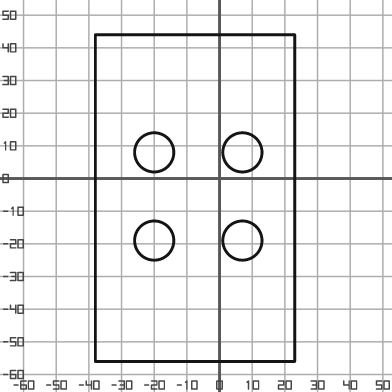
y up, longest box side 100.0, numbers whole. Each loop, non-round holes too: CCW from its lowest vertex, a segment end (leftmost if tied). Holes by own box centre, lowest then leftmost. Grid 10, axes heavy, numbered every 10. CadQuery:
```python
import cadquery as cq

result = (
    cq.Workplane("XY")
    .moveTo(-38.0, -56.0)
    .lineTo(23.0, -56.0)
    .lineTo(23.0, 44.0)
    .lineTo(-38.0, 44.0)
    .close()
    .moveTo(-20.0, -19.0)
    .circle(6.0)
    .moveTo(7.0, -19.0)
    .circle(6.0)
    .moveTo(-20.0, 8.0)
    .circle(6.0)
    .moveTo(7.0, 8.0)
    .circle(6.0)
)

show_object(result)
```